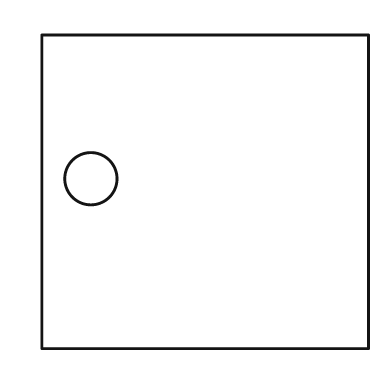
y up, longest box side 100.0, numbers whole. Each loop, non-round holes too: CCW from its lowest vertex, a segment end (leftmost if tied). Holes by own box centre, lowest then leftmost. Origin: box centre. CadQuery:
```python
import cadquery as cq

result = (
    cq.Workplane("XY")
    .moveTo(-50.0, -48.0)
    .lineTo(50.0, -48.0)
    .lineTo(50.0, 48.0)
    .lineTo(-50.0, 48.0)
    .close()
    .moveTo(-35.0, 4.0)
    .circle(8.0)
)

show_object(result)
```